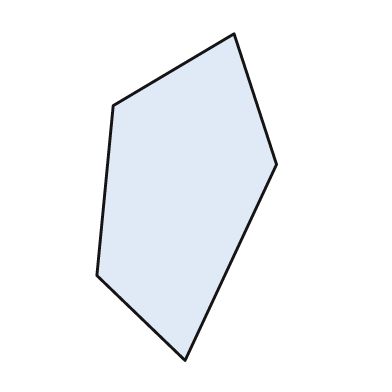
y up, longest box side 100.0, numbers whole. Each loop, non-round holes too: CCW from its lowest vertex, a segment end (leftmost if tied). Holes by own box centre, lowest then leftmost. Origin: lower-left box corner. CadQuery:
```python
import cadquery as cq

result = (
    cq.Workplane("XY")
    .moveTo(27.0, 0.0)
    .lineTo(55.0, 60.0)
    .lineTo(42.0, 100.0)
    .lineTo(5.0, 78.0)
    .lineTo(0.0, 26.0)
    .close()
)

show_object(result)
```